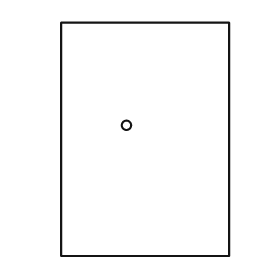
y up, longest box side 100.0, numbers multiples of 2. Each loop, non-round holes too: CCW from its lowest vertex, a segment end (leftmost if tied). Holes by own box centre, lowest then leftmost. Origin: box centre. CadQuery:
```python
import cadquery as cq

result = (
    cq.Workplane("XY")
    .moveTo(-36.0, -50.0)
    .lineTo(36.0, -50.0)
    .lineTo(36.0, 50.0)
    .lineTo(-36.0, 50.0)
    .close()
    .moveTo(-8.0, 6.0)
    .circle(2.0)
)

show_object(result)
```